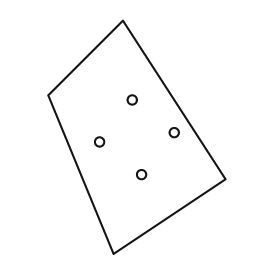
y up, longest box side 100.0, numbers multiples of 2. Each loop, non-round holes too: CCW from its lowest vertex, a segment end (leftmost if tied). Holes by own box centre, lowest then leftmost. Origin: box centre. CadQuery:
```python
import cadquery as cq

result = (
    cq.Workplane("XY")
    .moveTo(-10.0, -50.0)
    .lineTo(38.0, -18.0)
    .lineTo(-6.0, 50.0)
    .lineTo(-38.0, 18.0)
    .close()
    .moveTo(2.0, -16.0)
    .circle(2.0)
    .moveTo(-16.0, -2.0)
    .circle(2.0)
    .moveTo(16.0, 2.0)
    .circle(2.0)
    .moveTo(-2.0, 16.0)
    .circle(2.0)
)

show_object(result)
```